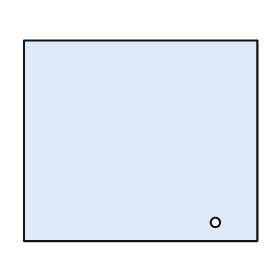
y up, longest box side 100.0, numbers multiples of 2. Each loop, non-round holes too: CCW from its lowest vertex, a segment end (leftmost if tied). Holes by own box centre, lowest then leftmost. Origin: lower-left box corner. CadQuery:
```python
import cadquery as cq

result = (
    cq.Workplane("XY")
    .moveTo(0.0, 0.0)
    .lineTo(100.0, 0.0)
    .lineTo(100.0, 86.0)
    .lineTo(0.0, 86.0)
    .close()
    .moveTo(82.0, 8.0)
    .circle(2.0)
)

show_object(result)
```